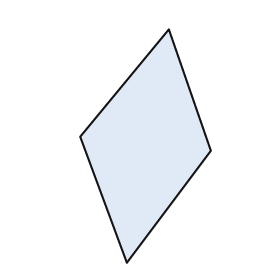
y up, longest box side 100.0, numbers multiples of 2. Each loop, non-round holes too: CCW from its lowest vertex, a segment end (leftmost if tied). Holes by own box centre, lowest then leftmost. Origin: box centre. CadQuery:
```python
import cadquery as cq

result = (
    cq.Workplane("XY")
    .moveTo(-8.0, -50.0)
    .lineTo(28.0, -2.0)
    .lineTo(10.0, 50.0)
    .lineTo(-28.0, 4.0)
    .close()
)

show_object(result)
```